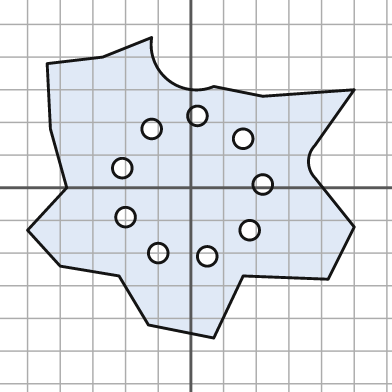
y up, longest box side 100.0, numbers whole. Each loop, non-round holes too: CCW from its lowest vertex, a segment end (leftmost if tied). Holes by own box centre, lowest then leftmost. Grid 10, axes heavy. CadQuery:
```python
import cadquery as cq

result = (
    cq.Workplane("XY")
    .moveTo(7.0, -46.0)
    .lineTo(16.0, -27.0)
    .lineTo(42.0, -28.0)
    .lineTo(50.0, -12.0)
    .lineTo(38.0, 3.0)
    .threePointArc((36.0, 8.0), (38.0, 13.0))
    .lineTo(50.0, 30.0)
    .lineTo(22.0, 28.0)
    .lineTo(7.0, 31.0)
    .threePointArc((-7.0, 33.0), (-12.0, 46.0))
    .lineTo(-27.0, 40.0)
    .lineTo(-44.0, 38.0)
    .lineTo(-43.0, 18.0)
    .lineTo(-38.0, 0.0)
    .lineTo(-50.0, -13.0)
    .lineTo(-40.0, -24.0)
    .lineTo(-22.0, -27.0)
    .lineTo(-13.0, -42.0)
    .close()
    .moveTo(5.0, -21.0)
    .circle(3.0)
    .moveTo(-10.0, -20.0)
    .circle(3.0)
    .moveTo(18.0, -13.0)
    .circle(3.0)
    .moveTo(-20.0, -9.0)
    .circle(3.0)
    .moveTo(22.0, 1.0)
    .circle(3.0)
    .moveTo(-21.0, 6.0)
    .circle(3.0)
    .moveTo(16.0, 15.0)
    .circle(3.0)
    .moveTo(-12.0, 18.0)
    .circle(3.0)
    .moveTo(2.0, 22.0)
    .circle(3.0)
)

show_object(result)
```